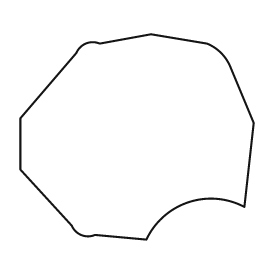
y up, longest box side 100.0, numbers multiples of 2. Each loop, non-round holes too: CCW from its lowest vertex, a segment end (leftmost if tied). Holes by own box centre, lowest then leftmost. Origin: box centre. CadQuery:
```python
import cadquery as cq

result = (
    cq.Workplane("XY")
    .moveTo(4.0, -44.0)
    .threePointArc((22.0, -28.0), (46.0, -30.0))
    .lineTo(50.0, 6.0)
    .lineTo(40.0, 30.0)
    .threePointArc((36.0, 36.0), (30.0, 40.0))
    .lineTo(6.0, 44.0)
    .lineTo(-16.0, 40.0)
    .threePointArc((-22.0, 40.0), (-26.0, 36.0))
    .lineTo(-50.0, 8.0)
    .lineTo(-50.0, -14.0)
    .lineTo(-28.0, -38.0)
    .threePointArc((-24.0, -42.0), (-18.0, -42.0))
    .close()
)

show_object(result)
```